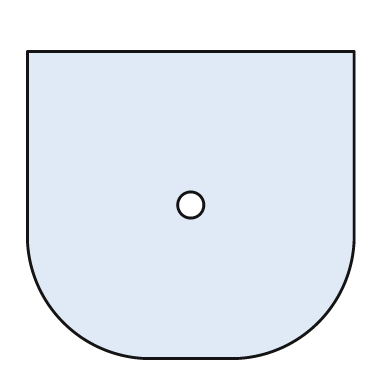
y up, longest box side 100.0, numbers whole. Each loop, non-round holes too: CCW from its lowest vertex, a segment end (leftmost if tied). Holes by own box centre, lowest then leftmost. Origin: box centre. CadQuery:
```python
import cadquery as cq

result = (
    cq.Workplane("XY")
    .moveTo(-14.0, -47.0)
    .lineTo(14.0, -47.0)
    .threePointArc((39.0, -36.0), (50.0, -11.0))
    .lineTo(50.0, 47.0)
    .lineTo(-50.0, 47.0)
    .lineTo(-50.0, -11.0)
    .threePointArc((-39.0, -36.0), (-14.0, -47.0))
    .close()
    .moveTo(0.0, 0.0)
    .circle(4.0)
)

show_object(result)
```